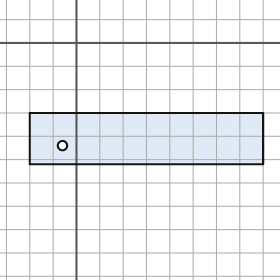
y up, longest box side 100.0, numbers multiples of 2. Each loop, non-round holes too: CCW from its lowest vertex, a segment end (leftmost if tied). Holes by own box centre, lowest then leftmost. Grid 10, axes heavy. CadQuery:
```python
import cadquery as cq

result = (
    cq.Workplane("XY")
    .moveTo(-20.0, -52.0)
    .lineTo(80.0, -52.0)
    .lineTo(80.0, -30.0)
    .lineTo(-20.0, -30.0)
    .close()
    .moveTo(-6.0, -44.0)
    .circle(2.0)
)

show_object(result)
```